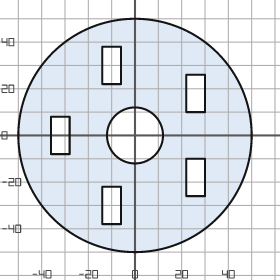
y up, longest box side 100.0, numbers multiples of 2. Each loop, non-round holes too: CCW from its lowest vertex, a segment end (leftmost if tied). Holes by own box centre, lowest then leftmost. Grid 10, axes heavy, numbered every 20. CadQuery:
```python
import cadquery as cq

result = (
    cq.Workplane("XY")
    .moveTo(0.0, 0.0)
    .circle(50.0)
    .moveTo(-14.0, -38.0)
    .lineTo(-6.0, -38.0)
    .lineTo(-6.0, -22.0)
    .lineTo(-14.0, -22.0)
    .close()
    .moveTo(22.0, -26.0)
    .lineTo(30.0, -26.0)
    .lineTo(30.0, -10.0)
    .lineTo(22.0, -10.0)
    .close()
    .moveTo(-36.0, -8.0)
    .lineTo(-28.0, -8.0)
    .lineTo(-28.0, 8.0)
    .lineTo(-36.0, 8.0)
    .close()
    .moveTo(0.0, 0.0)
    .circle(12.0)
    .moveTo(22.0, 10.0)
    .lineTo(30.0, 10.0)
    .lineTo(30.0, 26.0)
    .lineTo(22.0, 26.0)
    .close()
    .moveTo(-14.0, 22.0)
    .lineTo(-6.0, 22.0)
    .lineTo(-6.0, 38.0)
    .lineTo(-14.0, 38.0)
    .close()
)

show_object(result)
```